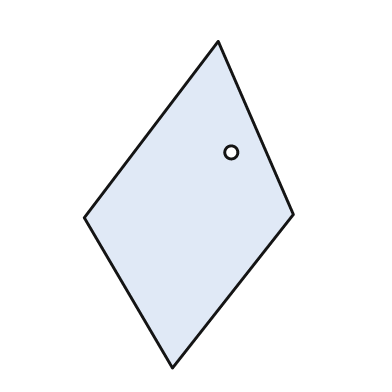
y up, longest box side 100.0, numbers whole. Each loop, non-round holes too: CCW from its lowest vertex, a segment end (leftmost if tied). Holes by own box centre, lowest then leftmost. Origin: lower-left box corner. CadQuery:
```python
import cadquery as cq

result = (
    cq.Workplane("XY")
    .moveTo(27.0, 0.0)
    .lineTo(64.0, 47.0)
    .lineTo(41.0, 100.0)
    .lineTo(0.0, 46.0)
    .close()
    .moveTo(45.0, 66.0)
    .circle(2.0)
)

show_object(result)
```